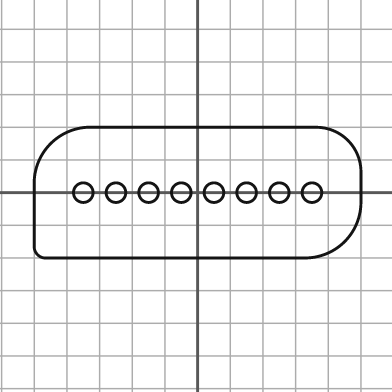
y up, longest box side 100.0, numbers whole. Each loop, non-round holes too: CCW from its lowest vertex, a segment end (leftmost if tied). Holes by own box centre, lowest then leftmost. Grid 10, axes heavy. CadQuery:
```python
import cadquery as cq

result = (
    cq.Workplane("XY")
    .moveTo(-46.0, -20.0)
    .lineTo(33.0, -20.0)
    .threePointArc((45.0, -15.0), (50.0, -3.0))
    .lineTo(50.0, 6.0)
    .threePointArc((46.0, 16.0), (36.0, 20.0))
    .lineTo(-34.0, 20.0)
    .threePointArc((-45.0, 15.0), (-50.0, 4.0))
    .lineTo(-50.0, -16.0)
    .threePointArc((-49.0, -19.0), (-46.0, -20.0))
    .close()
    .moveTo(-35.0, 0.0)
    .circle(3.0)
    .moveTo(-25.0, 0.0)
    .circle(3.0)
    .moveTo(-15.0, 0.0)
    .circle(3.0)
    .moveTo(-5.0, 0.0)
    .circle(3.0)
    .moveTo(5.0, 0.0)
    .circle(3.0)
    .moveTo(15.0, 0.0)
    .circle(3.0)
    .moveTo(25.0, 0.0)
    .circle(3.0)
    .moveTo(35.0, 0.0)
    .circle(3.0)
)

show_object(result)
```